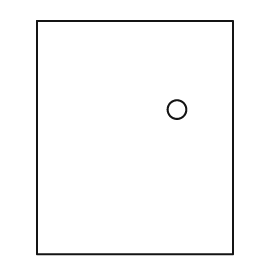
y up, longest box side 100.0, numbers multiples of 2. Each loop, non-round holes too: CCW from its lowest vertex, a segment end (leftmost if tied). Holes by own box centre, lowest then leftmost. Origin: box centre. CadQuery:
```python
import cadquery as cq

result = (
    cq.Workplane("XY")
    .moveTo(-42.0, -50.0)
    .lineTo(42.0, -50.0)
    .lineTo(42.0, 50.0)
    .lineTo(-42.0, 50.0)
    .close()
    .moveTo(18.0, 12.0)
    .circle(4.0)
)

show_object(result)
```